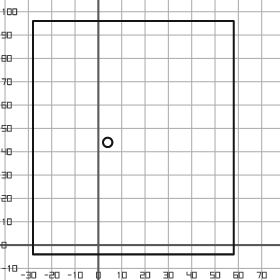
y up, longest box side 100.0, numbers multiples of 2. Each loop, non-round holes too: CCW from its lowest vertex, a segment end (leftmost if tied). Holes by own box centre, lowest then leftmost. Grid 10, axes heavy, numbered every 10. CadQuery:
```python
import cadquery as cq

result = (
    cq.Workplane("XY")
    .moveTo(-28.0, -4.0)
    .lineTo(58.0, -4.0)
    .lineTo(58.0, 96.0)
    .lineTo(-28.0, 96.0)
    .close()
    .moveTo(4.0, 44.0)
    .circle(2.0)
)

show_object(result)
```